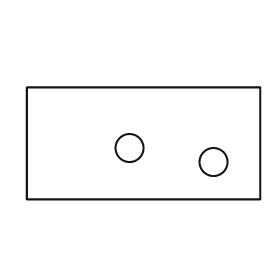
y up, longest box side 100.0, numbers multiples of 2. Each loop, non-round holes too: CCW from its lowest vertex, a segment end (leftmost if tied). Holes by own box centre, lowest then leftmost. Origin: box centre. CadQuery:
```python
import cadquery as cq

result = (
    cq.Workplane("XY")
    .moveTo(-50.0, -24.0)
    .lineTo(50.0, -24.0)
    .lineTo(50.0, 24.0)
    .lineTo(-50.0, 24.0)
    .close()
    .moveTo(30.0, -8.0)
    .circle(6.0)
    .moveTo(-6.0, -2.0)
    .circle(6.0)
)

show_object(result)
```